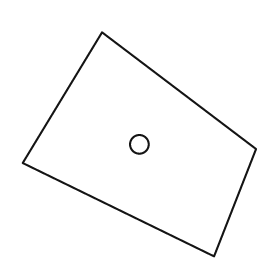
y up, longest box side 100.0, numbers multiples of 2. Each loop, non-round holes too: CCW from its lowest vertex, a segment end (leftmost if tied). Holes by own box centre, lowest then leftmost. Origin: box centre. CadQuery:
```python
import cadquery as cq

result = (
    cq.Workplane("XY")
    .moveTo(32.0, -48.0)
    .lineTo(50.0, -2.0)
    .lineTo(-16.0, 48.0)
    .lineTo(-50.0, -8.0)
    .close()
    .moveTo(0.0, 0.0)
    .circle(4.0)
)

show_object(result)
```